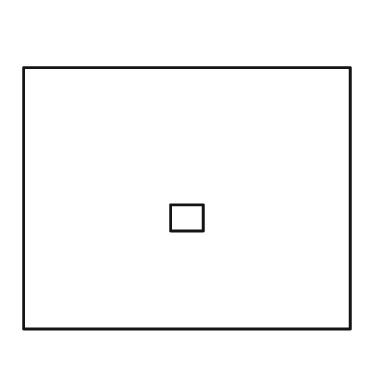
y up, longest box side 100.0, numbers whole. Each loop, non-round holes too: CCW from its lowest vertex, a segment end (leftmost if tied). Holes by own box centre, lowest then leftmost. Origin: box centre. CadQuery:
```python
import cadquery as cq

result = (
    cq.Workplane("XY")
    .moveTo(-50.0, -40.0)
    .lineTo(50.0, -40.0)
    .lineTo(50.0, 40.0)
    .lineTo(-50.0, 40.0)
    .close()
    .moveTo(-5.0, -10.0)
    .lineTo(5.0, -10.0)
    .lineTo(5.0, -2.0)
    .lineTo(-5.0, -2.0)
    .close()
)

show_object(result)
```